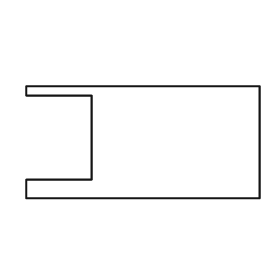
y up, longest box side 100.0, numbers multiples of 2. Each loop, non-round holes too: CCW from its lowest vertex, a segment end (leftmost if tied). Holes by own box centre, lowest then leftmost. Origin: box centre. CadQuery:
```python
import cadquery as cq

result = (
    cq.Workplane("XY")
    .moveTo(-50.0, -24.0)
    .lineTo(50.0, -24.0)
    .lineTo(50.0, 24.0)
    .lineTo(-50.0, 24.0)
    .lineTo(-50.0, 20.0)
    .lineTo(-22.0, 20.0)
    .lineTo(-22.0, -16.0)
    .lineTo(-50.0, -16.0)
    .close()
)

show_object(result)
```